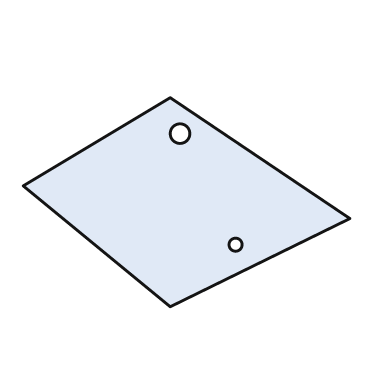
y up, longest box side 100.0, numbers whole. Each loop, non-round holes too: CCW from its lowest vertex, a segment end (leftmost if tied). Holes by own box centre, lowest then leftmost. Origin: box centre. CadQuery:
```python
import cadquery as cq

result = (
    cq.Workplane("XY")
    .moveTo(-5.0, -32.0)
    .lineTo(50.0, -5.0)
    .lineTo(-5.0, 32.0)
    .lineTo(-50.0, 5.0)
    .close()
    .moveTo(15.0, -13.0)
    .circle(2.0)
    .moveTo(-2.0, 21.0)
    .circle(3.0)
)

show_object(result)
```